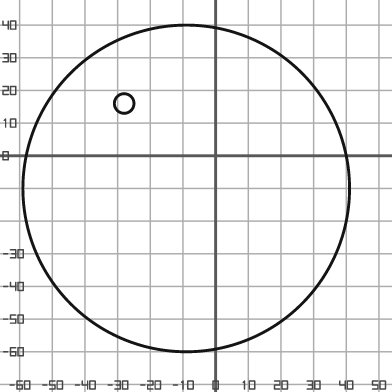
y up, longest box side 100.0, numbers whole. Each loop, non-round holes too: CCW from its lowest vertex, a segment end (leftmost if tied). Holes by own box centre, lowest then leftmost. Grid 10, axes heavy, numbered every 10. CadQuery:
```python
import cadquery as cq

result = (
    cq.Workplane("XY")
    .moveTo(-9.0, -10.0)
    .circle(50.0)
    .moveTo(-28.0, 16.0)
    .circle(3.0)
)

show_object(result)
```